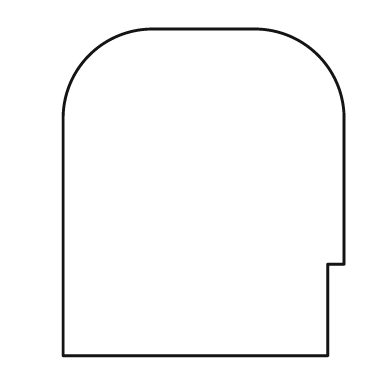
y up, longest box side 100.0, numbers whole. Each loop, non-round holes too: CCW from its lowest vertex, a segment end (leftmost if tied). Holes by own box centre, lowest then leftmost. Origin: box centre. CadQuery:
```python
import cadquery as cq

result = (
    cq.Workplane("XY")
    .moveTo(-43.0, -50.0)
    .lineTo(38.0, -50.0)
    .lineTo(38.0, -22.0)
    .lineTo(43.0, -22.0)
    .lineTo(43.0, 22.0)
    .threePointArc((35.0, 42.0), (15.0, 50.0))
    .lineTo(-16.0, 50.0)
    .threePointArc((-35.0, 42.0), (-43.0, 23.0))
    .close()
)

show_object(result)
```